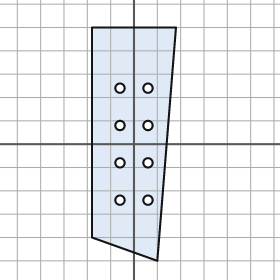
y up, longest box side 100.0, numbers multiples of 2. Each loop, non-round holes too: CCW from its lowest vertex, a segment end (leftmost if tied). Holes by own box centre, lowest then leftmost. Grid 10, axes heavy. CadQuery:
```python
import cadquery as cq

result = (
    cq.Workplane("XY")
    .moveTo(10.0, -50.0)
    .lineTo(18.0, 50.0)
    .lineTo(-18.0, 50.0)
    .lineTo(-18.0, -40.0)
    .close()
    .moveTo(-6.0, -24.0)
    .circle(2.0)
    .moveTo(6.0, -24.0)
    .circle(2.0)
    .moveTo(-6.0, -8.0)
    .circle(2.0)
    .moveTo(6.0, -8.0)
    .circle(2.0)
    .moveTo(-6.0, 8.0)
    .circle(2.0)
    .moveTo(6.0, 8.0)
    .circle(2.0)
    .moveTo(-6.0, 24.0)
    .circle(2.0)
    .moveTo(6.0, 24.0)
    .circle(2.0)
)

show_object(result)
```